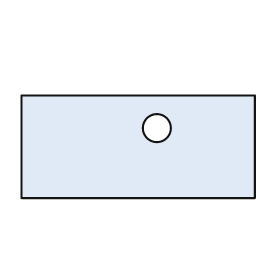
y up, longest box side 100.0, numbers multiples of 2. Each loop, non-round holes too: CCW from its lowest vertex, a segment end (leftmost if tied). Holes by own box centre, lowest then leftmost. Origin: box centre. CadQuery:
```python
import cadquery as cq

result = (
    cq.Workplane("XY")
    .moveTo(-50.0, -22.0)
    .lineTo(50.0, -22.0)
    .lineTo(50.0, 22.0)
    .lineTo(-50.0, 22.0)
    .close()
    .moveTo(8.0, 8.0)
    .circle(6.0)
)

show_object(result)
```